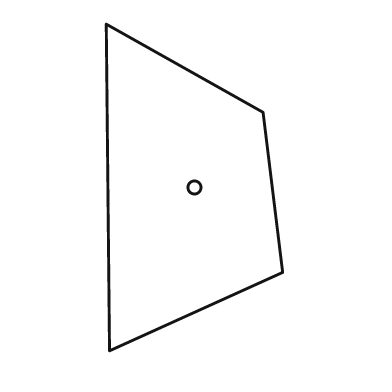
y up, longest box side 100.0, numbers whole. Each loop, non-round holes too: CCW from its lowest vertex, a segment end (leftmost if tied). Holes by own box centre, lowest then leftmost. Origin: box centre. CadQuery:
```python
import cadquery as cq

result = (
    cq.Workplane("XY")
    .moveTo(-26.0, -50.0)
    .lineTo(27.0, -26.0)
    .lineTo(21.0, 23.0)
    .lineTo(-27.0, 50.0)
    .close()
    .moveTo(0.0, 0.0)
    .circle(2.0)
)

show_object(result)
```